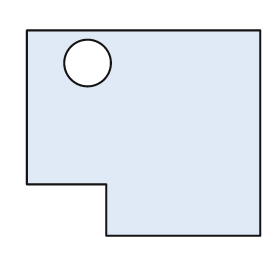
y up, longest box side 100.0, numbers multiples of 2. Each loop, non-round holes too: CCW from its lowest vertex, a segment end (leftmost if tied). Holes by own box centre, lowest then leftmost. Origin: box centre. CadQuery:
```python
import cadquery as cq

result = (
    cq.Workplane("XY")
    .moveTo(-16.0, -44.0)
    .lineTo(50.0, -44.0)
    .lineTo(50.0, 44.0)
    .lineTo(-50.0, 44.0)
    .lineTo(-50.0, -22.0)
    .lineTo(-16.0, -22.0)
    .close()
    .moveTo(-24.0, 30.0)
    .circle(10.0)
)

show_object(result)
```